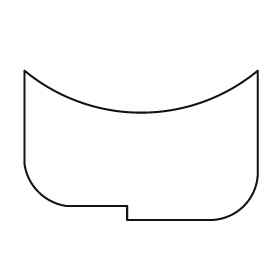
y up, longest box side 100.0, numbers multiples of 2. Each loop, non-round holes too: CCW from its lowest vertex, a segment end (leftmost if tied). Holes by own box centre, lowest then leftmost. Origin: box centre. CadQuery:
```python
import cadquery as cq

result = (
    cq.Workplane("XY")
    .moveTo(-6.0, -32.0)
    .lineTo(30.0, -32.0)
    .threePointArc((44.0, -26.0), (50.0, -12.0))
    .lineTo(50.0, 32.0)
    .threePointArc((0.0, 14.0), (-50.0, 32.0))
    .lineTo(-50.0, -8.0)
    .threePointArc((-44.0, -20.0), (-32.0, -26.0))
    .lineTo(-6.0, -26.0)
    .close()
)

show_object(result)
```